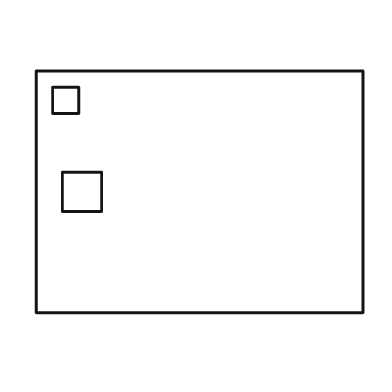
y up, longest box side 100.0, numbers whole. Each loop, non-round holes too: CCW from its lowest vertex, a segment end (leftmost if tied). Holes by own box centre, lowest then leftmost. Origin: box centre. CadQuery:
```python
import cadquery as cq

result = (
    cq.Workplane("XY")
    .moveTo(-50.0, -37.0)
    .lineTo(50.0, -37.0)
    .lineTo(50.0, 37.0)
    .lineTo(-50.0, 37.0)
    .close()
    .moveTo(-42.0, -6.0)
    .lineTo(-30.0, -6.0)
    .lineTo(-30.0, 6.0)
    .lineTo(-42.0, 6.0)
    .close()
    .moveTo(-45.0, 24.0)
    .lineTo(-37.0, 24.0)
    .lineTo(-37.0, 32.0)
    .lineTo(-45.0, 32.0)
    .close()
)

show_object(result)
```